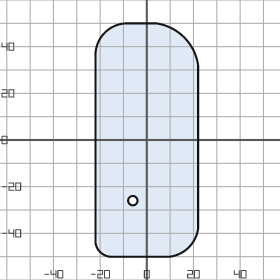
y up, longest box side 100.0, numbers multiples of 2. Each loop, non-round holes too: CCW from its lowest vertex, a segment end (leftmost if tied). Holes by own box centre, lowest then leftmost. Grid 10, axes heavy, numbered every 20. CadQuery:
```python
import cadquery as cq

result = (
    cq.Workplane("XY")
    .moveTo(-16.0, -50.0)
    .lineTo(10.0, -50.0)
    .threePointArc((18.0, -46.0), (22.0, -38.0))
    .lineTo(22.0, 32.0)
    .threePointArc((16.0, 44.0), (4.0, 50.0))
    .lineTo(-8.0, 50.0)
    .threePointArc((-18.0, 46.0), (-22.0, 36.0))
    .lineTo(-22.0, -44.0)
    .threePointArc((-20.0, -48.0), (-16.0, -50.0))
    .close()
    .moveTo(-6.0, -26.0)
    .circle(2.0)
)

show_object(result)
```